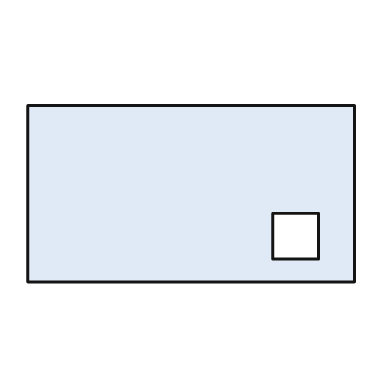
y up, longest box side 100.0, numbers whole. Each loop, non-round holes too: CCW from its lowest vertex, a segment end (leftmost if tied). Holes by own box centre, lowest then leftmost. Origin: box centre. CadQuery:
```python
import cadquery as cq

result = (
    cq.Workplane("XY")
    .moveTo(-50.0, -27.0)
    .lineTo(50.0, -27.0)
    .lineTo(50.0, 27.0)
    .lineTo(-50.0, 27.0)
    .close()
    .moveTo(25.0, -20.0)
    .lineTo(39.0, -20.0)
    .lineTo(39.0, -6.0)
    .lineTo(25.0, -6.0)
    .close()
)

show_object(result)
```